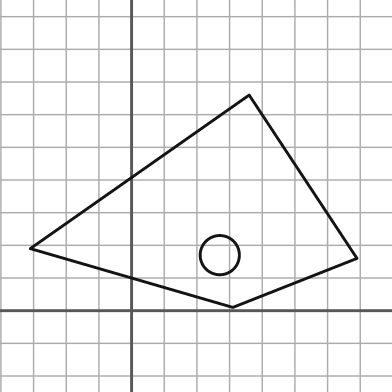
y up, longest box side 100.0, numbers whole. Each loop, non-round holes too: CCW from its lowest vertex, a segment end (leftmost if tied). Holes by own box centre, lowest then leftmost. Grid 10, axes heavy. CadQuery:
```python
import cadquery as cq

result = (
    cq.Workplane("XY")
    .moveTo(31.0, 1.0)
    .lineTo(69.0, 16.0)
    .lineTo(36.0, 66.0)
    .lineTo(-31.0, 19.0)
    .close()
    .moveTo(27.0, 17.0)
    .circle(6.0)
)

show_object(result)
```